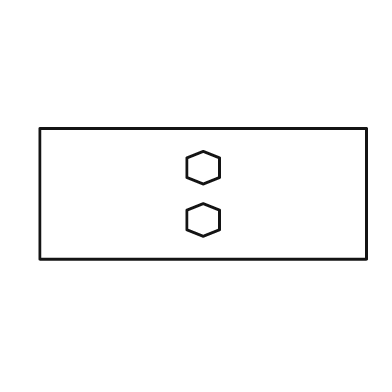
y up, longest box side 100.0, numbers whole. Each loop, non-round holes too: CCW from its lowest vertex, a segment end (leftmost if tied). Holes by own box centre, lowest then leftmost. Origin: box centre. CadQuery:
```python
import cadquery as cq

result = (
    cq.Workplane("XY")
    .moveTo(-50.0, -20.0)
    .lineTo(50.0, -20.0)
    .lineTo(50.0, 20.0)
    .lineTo(-50.0, 20.0)
    .close()
    .moveTo(0.0, -13.0)
    .lineTo(5.0, -11.0)
    .lineTo(5.0, -5.0)
    .lineTo(0.0, -3.0)
    .lineTo(-5.0, -5.0)
    .lineTo(-5.0, -11.0)
    .close()
    .moveTo(0.0, 3.0)
    .lineTo(5.0, 5.0)
    .lineTo(5.0, 11.0)
    .lineTo(0.0, 13.0)
    .lineTo(-5.0, 11.0)
    .lineTo(-5.0, 5.0)
    .close()
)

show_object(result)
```